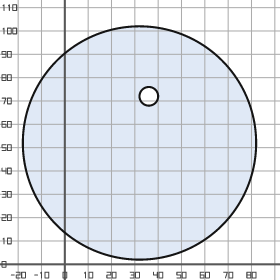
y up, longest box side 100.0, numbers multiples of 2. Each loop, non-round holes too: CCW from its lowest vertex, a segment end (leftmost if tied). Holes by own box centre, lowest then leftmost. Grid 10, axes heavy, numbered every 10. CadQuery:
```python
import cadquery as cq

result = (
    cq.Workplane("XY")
    .moveTo(32.0, 52.0)
    .circle(50.0)
    .moveTo(36.0, 72.0)
    .circle(4.0)
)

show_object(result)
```